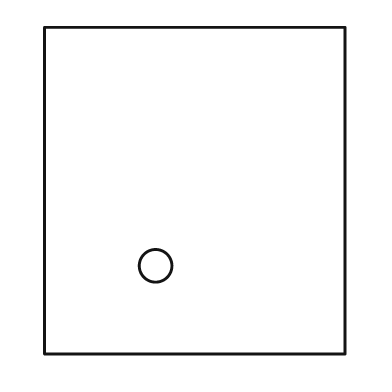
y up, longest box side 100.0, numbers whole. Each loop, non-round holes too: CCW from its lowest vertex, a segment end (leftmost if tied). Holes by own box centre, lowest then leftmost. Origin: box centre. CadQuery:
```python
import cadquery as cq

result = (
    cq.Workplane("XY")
    .moveTo(-46.0, -50.0)
    .lineTo(46.0, -50.0)
    .lineTo(46.0, 50.0)
    .lineTo(-46.0, 50.0)
    .close()
    .moveTo(-12.0, -23.0)
    .circle(5.0)
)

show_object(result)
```